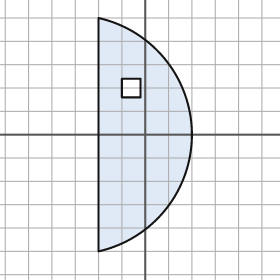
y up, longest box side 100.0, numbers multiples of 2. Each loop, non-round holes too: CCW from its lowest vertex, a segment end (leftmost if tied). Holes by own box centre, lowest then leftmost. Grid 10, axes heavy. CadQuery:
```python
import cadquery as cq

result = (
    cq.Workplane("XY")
    .moveTo(-20.0, -50.0)
    .threePointArc((20.0, 0.0), (-20.0, 50.0))
    .close()
    .moveTo(-10.0, 16.0)
    .lineTo(-2.0, 16.0)
    .lineTo(-2.0, 24.0)
    .lineTo(-10.0, 24.0)
    .close()
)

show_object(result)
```